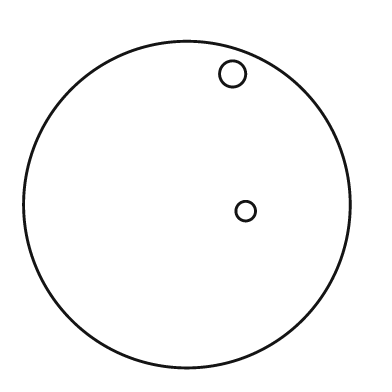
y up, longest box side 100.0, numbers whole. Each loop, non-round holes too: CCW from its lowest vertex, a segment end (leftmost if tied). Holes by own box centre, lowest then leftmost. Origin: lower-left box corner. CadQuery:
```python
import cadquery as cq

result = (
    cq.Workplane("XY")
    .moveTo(50.0, 50.0)
    .circle(50.0)
    .moveTo(68.0, 48.0)
    .circle(3.0)
    .moveTo(64.0, 90.0)
    .circle(4.0)
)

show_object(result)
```